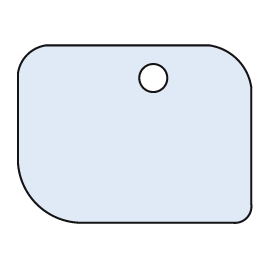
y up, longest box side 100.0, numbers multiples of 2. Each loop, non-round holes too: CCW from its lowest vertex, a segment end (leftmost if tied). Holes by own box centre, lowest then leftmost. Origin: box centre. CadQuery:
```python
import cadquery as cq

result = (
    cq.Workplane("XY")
    .moveTo(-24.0, -38.0)
    .lineTo(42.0, -38.0)
    .threePointArc((48.0, -36.0), (50.0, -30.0))
    .lineTo(50.0, 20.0)
    .threePointArc((44.0, 32.0), (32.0, 38.0))
    .lineTo(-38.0, 38.0)
    .threePointArc((-46.0, 34.0), (-50.0, 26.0))
    .lineTo(-50.0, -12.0)
    .threePointArc((-42.0, -30.0), (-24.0, -38.0))
    .close()
    .moveTo(8.0, 24.0)
    .circle(6.0)
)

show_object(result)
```